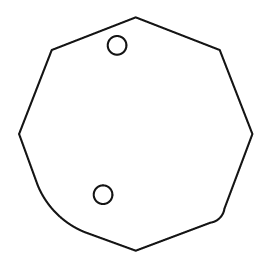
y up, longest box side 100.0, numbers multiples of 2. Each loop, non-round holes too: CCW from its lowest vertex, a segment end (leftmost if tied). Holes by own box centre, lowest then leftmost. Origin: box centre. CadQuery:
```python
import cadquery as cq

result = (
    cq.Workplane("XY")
    .moveTo(0.0, -50.0)
    .lineTo(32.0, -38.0)
    .threePointArc((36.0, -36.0), (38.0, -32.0))
    .lineTo(50.0, 0.0)
    .lineTo(36.0, 36.0)
    .lineTo(0.0, 50.0)
    .lineTo(-36.0, 36.0)
    .lineTo(-50.0, 0.0)
    .lineTo(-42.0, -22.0)
    .threePointArc((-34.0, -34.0), (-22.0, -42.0))
    .close()
    .moveTo(-14.0, -26.0)
    .circle(4.0)
    .moveTo(-8.0, 38.0)
    .circle(4.0)
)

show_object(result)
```